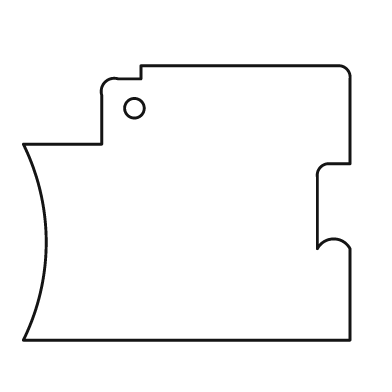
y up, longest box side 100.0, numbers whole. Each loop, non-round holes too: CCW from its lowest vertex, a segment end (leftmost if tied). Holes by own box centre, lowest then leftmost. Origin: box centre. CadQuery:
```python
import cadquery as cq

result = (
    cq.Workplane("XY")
    .moveTo(-50.0, -42.0)
    .lineTo(50.0, -42.0)
    .lineTo(50.0, -14.0)
    .threePointArc((45.0, -11.0), (40.0, -14.0))
    .lineTo(40.0, 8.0)
    .threePointArc((41.0, 11.0), (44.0, 12.0))
    .lineTo(50.0, 12.0)
    .lineTo(50.0, 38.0)
    .threePointArc((49.0, 41.0), (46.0, 42.0))
    .lineTo(-14.0, 42.0)
    .lineTo(-14.0, 38.0)
    .lineTo(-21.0, 38.0)
    .threePointArc((-25.0, 37.0), (-26.0, 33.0))
    .lineTo(-26.0, 18.0)
    .lineTo(-50.0, 18.0)
    .threePointArc((-43.0, -12.0), (-50.0, -42.0))
    .close()
    .moveTo(-16.0, 29.0)
    .circle(3.0)
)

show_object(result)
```